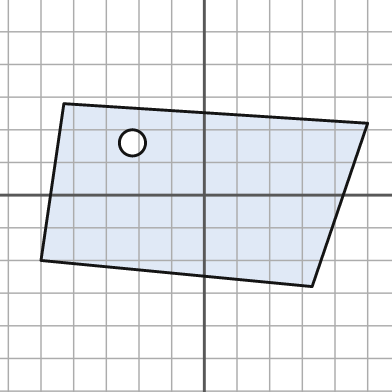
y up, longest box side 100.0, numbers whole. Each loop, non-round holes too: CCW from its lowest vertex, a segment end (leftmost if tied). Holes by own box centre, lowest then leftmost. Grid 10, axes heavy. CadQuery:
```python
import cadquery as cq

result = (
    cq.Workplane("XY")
    .moveTo(33.0, -28.0)
    .lineTo(50.0, 22.0)
    .lineTo(-43.0, 28.0)
    .lineTo(-50.0, -20.0)
    .close()
    .moveTo(-22.0, 16.0)
    .circle(4.0)
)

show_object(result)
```